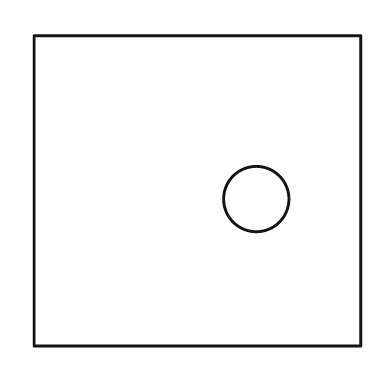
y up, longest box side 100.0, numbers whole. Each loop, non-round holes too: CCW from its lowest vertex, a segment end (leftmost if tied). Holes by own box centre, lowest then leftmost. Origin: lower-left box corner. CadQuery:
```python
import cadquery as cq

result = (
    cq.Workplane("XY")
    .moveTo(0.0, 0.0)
    .lineTo(100.0, 0.0)
    .lineTo(100.0, 95.0)
    .lineTo(0.0, 95.0)
    .close()
    .moveTo(68.0, 45.0)
    .circle(10.0)
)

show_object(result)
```